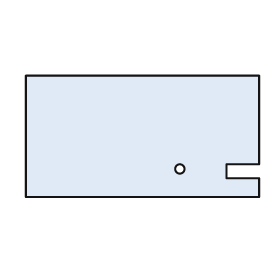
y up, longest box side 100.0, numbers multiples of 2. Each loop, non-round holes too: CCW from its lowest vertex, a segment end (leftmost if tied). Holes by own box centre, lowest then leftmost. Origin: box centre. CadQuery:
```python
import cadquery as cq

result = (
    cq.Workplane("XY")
    .moveTo(-50.0, -26.0)
    .lineTo(50.0, -26.0)
    .lineTo(50.0, -18.0)
    .lineTo(36.0, -18.0)
    .lineTo(36.0, -12.0)
    .lineTo(50.0, -12.0)
    .lineTo(50.0, 26.0)
    .lineTo(-50.0, 26.0)
    .close()
    .moveTo(16.0, -14.0)
    .circle(2.0)
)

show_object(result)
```